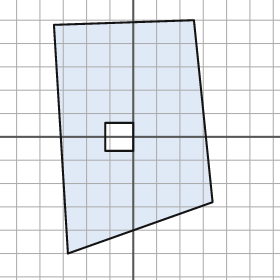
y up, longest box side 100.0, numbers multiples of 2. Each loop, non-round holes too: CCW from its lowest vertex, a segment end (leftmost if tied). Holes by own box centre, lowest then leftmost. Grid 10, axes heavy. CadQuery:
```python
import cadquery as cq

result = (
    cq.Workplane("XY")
    .moveTo(-28.0, -50.0)
    .lineTo(34.0, -28.0)
    .lineTo(26.0, 50.0)
    .lineTo(-34.0, 48.0)
    .close()
    .moveTo(-12.0, -6.0)
    .lineTo(0.0, -6.0)
    .lineTo(0.0, 6.0)
    .lineTo(-12.0, 6.0)
    .close()
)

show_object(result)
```